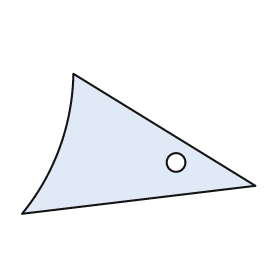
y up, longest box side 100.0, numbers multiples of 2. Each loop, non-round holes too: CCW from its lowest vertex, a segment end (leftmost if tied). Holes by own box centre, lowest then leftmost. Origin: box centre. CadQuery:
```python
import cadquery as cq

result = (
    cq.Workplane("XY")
    .moveTo(-50.0, -30.0)
    .lineTo(50.0, -18.0)
    .lineTo(-28.0, 30.0)
    .threePointArc((-34.0, -2.0), (-50.0, -30.0))
    .close()
    .moveTo(16.0, -8.0)
    .circle(4.0)
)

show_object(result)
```